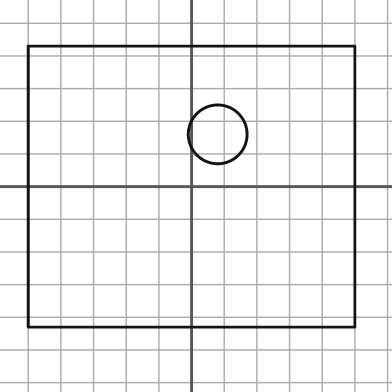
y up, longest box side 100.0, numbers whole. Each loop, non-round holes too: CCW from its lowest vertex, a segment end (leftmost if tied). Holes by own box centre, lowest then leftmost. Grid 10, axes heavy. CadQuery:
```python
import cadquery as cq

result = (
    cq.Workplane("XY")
    .moveTo(-50.0, -43.0)
    .lineTo(50.0, -43.0)
    .lineTo(50.0, 43.0)
    .lineTo(-50.0, 43.0)
    .close()
    .moveTo(8.0, 16.0)
    .circle(9.0)
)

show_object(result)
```